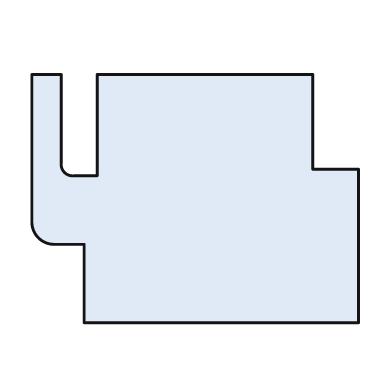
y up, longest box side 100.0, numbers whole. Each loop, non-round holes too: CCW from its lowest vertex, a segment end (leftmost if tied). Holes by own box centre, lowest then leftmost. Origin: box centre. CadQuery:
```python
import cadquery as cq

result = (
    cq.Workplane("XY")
    .moveTo(-34.0, -38.0)
    .lineTo(50.0, -38.0)
    .lineTo(50.0, 9.0)
    .lineTo(36.0, 9.0)
    .lineTo(36.0, 38.0)
    .lineTo(-30.0, 38.0)
    .lineTo(-30.0, 7.0)
    .lineTo(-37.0, 7.0)
    .threePointArc((-40.0, 8.0), (-41.0, 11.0))
    .lineTo(-41.0, 38.0)
    .lineTo(-50.0, 38.0)
    .lineTo(-50.0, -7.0)
    .threePointArc((-48.0, -12.0), (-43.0, -14.0))
    .lineTo(-34.0, -14.0)
    .close()
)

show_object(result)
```